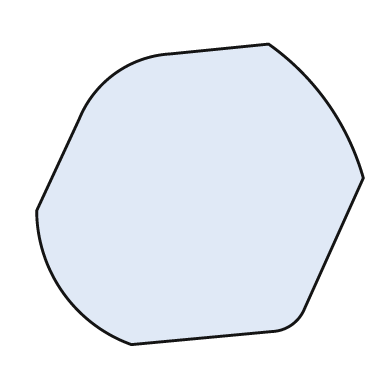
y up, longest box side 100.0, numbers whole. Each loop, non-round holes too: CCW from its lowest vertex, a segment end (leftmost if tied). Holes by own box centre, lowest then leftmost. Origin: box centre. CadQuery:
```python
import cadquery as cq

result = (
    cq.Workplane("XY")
    .moveTo(-21.0, -46.0)
    .lineTo(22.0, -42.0)
    .threePointArc((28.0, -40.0), (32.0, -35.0))
    .lineTo(50.0, 5.0)
    .threePointArc((39.0, 28.0), (21.0, 46.0))
    .lineTo(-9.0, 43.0)
    .threePointArc((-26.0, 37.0), (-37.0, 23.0))
    .lineTo(-50.0, -5.0)
    .threePointArc((-42.0, -30.0), (-21.0, -46.0))
    .close()
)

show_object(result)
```